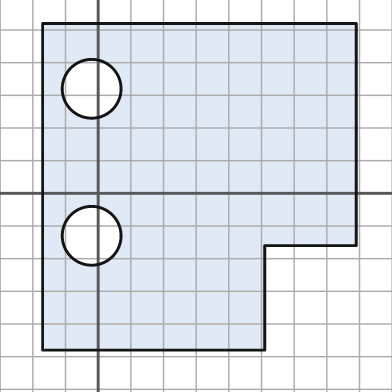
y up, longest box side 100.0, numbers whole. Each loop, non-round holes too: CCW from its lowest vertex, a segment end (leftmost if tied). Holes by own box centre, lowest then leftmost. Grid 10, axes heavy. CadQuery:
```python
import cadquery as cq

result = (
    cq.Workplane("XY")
    .moveTo(-17.0, -48.0)
    .lineTo(51.0, -48.0)
    .lineTo(51.0, -16.0)
    .lineTo(79.0, -16.0)
    .lineTo(79.0, 52.0)
    .lineTo(-17.0, 52.0)
    .close()
    .moveTo(-2.0, -13.0)
    .circle(9.0)
    .moveTo(-2.0, 32.0)
    .circle(9.0)
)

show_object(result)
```